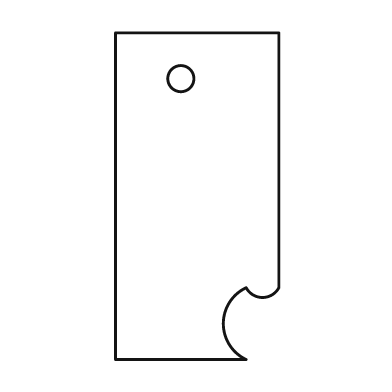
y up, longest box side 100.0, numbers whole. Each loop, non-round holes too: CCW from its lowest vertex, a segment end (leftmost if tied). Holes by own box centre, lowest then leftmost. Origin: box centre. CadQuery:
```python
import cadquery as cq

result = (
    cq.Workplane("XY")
    .moveTo(-25.0, -50.0)
    .lineTo(15.0, -50.0)
    .threePointArc((8.0, -39.0), (15.0, -28.0))
    .threePointArc((20.0, -31.0), (25.0, -28.0))
    .lineTo(25.0, 50.0)
    .lineTo(-25.0, 50.0)
    .close()
    .moveTo(-5.0, 36.0)
    .circle(4.0)
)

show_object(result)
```